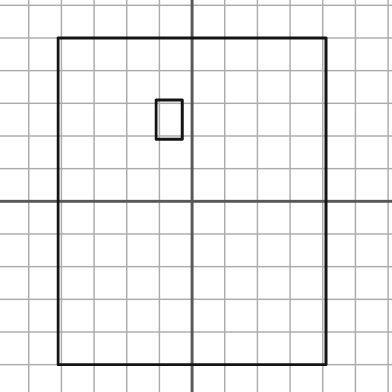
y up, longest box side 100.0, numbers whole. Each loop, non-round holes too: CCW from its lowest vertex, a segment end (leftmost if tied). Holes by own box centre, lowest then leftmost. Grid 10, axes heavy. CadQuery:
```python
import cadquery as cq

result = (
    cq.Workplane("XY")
    .moveTo(-41.0, -50.0)
    .lineTo(41.0, -50.0)
    .lineTo(41.0, 50.0)
    .lineTo(-41.0, 50.0)
    .close()
    .moveTo(-11.0, 19.0)
    .lineTo(-3.0, 19.0)
    .lineTo(-3.0, 31.0)
    .lineTo(-11.0, 31.0)
    .close()
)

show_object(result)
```